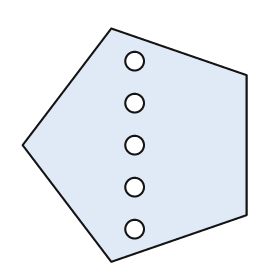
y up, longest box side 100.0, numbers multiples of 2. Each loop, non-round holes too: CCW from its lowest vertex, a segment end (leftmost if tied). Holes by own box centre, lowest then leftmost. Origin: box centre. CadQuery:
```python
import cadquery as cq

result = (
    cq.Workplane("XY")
    .moveTo(-10.0, -50.0)
    .lineTo(48.0, -30.0)
    .lineTo(48.0, 30.0)
    .lineTo(-10.0, 50.0)
    .lineTo(-48.0, 0.0)
    .close()
    .moveTo(0.0, -36.0)
    .circle(4.0)
    .moveTo(0.0, -18.0)
    .circle(4.0)
    .moveTo(0.0, 0.0)
    .circle(4.0)
    .moveTo(0.0, 18.0)
    .circle(4.0)
    .moveTo(0.0, 36.0)
    .circle(4.0)
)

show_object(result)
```